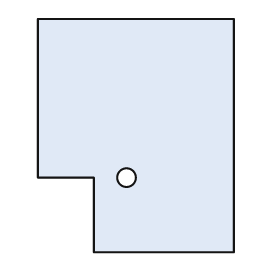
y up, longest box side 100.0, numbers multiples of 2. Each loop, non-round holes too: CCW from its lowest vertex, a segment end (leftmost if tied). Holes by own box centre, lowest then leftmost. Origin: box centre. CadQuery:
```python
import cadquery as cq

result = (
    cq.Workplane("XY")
    .moveTo(-18.0, -50.0)
    .lineTo(42.0, -50.0)
    .lineTo(42.0, 50.0)
    .lineTo(-42.0, 50.0)
    .lineTo(-42.0, -18.0)
    .lineTo(-18.0, -18.0)
    .close()
    .moveTo(-4.0, -18.0)
    .circle(4.0)
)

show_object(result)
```